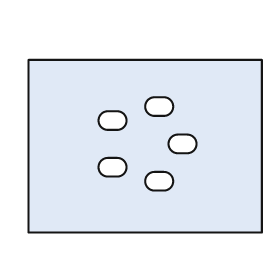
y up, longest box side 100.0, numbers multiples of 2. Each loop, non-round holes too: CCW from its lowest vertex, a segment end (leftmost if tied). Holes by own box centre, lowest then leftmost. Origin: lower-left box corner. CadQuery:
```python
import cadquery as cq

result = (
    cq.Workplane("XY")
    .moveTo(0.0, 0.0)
    .lineTo(100.0, 0.0)
    .lineTo(100.0, 74.0)
    .lineTo(0.0, 74.0)
    .close()
    .moveTo(54.0, 18.0)
    .lineTo(58.0, 18.0)
    .threePointArc((62.0, 22.0), (58.0, 26.0))
    .lineTo(54.0, 26.0)
    .threePointArc((50.0, 22.0), (54.0, 18.0))
    .close()
    .moveTo(34.0, 24.0)
    .lineTo(38.0, 24.0)
    .threePointArc((42.0, 28.0), (38.0, 32.0))
    .lineTo(34.0, 32.0)
    .threePointArc((30.0, 28.0), (34.0, 24.0))
    .close()
    .moveTo(64.0, 34.0)
    .lineTo(68.0, 34.0)
    .threePointArc((72.0, 38.0), (68.0, 42.0))
    .lineTo(64.0, 42.0)
    .threePointArc((60.0, 38.0), (64.0, 34.0))
    .close()
    .moveTo(34.0, 44.0)
    .lineTo(38.0, 44.0)
    .threePointArc((42.0, 48.0), (38.0, 52.0))
    .lineTo(34.0, 52.0)
    .threePointArc((30.0, 48.0), (34.0, 44.0))
    .close()
    .moveTo(54.0, 50.0)
    .lineTo(58.0, 50.0)
    .threePointArc((62.0, 54.0), (58.0, 58.0))
    .lineTo(54.0, 58.0)
    .threePointArc((50.0, 54.0), (54.0, 50.0))
    .close()
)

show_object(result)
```